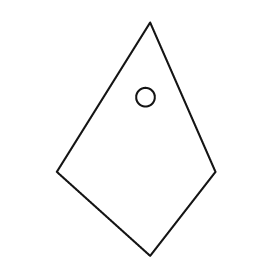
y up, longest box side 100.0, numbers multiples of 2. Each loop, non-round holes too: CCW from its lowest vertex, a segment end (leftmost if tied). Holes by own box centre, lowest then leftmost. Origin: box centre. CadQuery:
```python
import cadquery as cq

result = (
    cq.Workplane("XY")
    .moveTo(6.0, -50.0)
    .lineTo(34.0, -14.0)
    .lineTo(6.0, 50.0)
    .lineTo(-34.0, -14.0)
    .close()
    .moveTo(4.0, 18.0)
    .circle(4.0)
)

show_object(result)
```